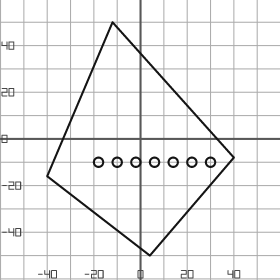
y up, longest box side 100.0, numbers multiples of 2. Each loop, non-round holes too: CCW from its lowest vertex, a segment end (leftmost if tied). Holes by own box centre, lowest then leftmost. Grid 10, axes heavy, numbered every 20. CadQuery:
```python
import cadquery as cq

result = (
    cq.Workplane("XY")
    .moveTo(4.0, -50.0)
    .lineTo(40.0, -8.0)
    .lineTo(-12.0, 50.0)
    .lineTo(-40.0, -16.0)
    .close()
    .moveTo(-18.0, -10.0)
    .circle(2.0)
    .moveTo(-10.0, -10.0)
    .circle(2.0)
    .moveTo(-2.0, -10.0)
    .circle(2.0)
    .moveTo(6.0, -10.0)
    .circle(2.0)
    .moveTo(14.0, -10.0)
    .circle(2.0)
    .moveTo(22.0, -10.0)
    .circle(2.0)
    .moveTo(30.0, -10.0)
    .circle(2.0)
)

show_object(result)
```